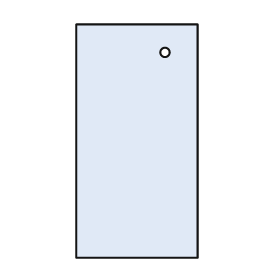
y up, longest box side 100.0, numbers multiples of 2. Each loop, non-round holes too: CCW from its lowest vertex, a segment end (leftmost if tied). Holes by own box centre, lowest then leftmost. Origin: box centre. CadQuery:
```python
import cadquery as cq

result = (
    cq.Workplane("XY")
    .moveTo(-26.0, -50.0)
    .lineTo(26.0, -50.0)
    .lineTo(26.0, 50.0)
    .lineTo(-26.0, 50.0)
    .close()
    .moveTo(12.0, 38.0)
    .circle(2.0)
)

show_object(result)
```